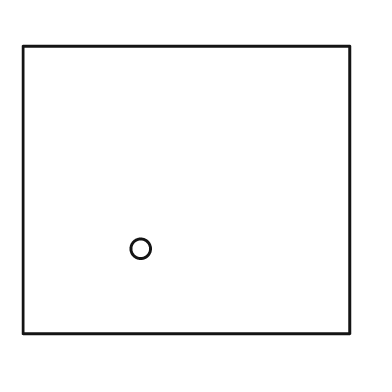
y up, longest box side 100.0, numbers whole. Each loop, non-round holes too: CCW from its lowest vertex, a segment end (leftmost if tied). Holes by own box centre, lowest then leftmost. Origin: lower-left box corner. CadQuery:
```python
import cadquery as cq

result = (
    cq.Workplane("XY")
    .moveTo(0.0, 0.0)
    .lineTo(100.0, 0.0)
    .lineTo(100.0, 88.0)
    .lineTo(0.0, 88.0)
    .close()
    .moveTo(36.0, 26.0)
    .circle(3.0)
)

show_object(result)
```